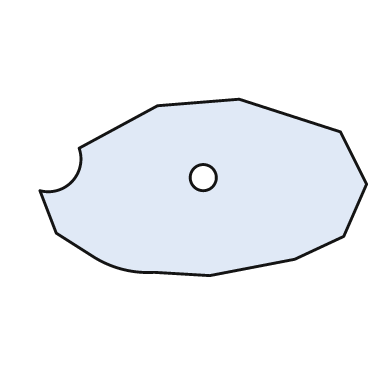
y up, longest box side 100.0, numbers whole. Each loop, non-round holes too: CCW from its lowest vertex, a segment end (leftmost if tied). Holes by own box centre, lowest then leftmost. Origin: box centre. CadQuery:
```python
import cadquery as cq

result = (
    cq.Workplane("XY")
    .moveTo(2.0, -27.0)
    .lineTo(28.0, -22.0)
    .lineTo(43.0, -15.0)
    .lineTo(50.0, 1.0)
    .lineTo(42.0, 17.0)
    .lineTo(11.0, 27.0)
    .lineTo(-14.0, 25.0)
    .lineTo(-38.0, 12.0)
    .threePointArc((-40.0, 2.0), (-50.0, -1.0))
    .lineTo(-45.0, -14.0)
    .lineTo(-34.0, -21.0)
    .threePointArc((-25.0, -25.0), (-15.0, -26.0))
    .close()
    .moveTo(0.0, 3.0)
    .circle(4.0)
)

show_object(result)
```